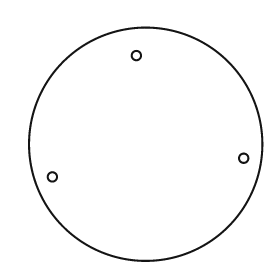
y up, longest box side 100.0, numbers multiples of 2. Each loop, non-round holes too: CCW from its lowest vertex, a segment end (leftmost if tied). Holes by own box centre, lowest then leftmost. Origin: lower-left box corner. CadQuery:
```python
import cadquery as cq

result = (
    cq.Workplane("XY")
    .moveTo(50.0, 50.0)
    .circle(50.0)
    .moveTo(10.0, 36.0)
    .circle(2.0)
    .moveTo(92.0, 44.0)
    .circle(2.0)
    .moveTo(46.0, 88.0)
    .circle(2.0)
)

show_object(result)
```